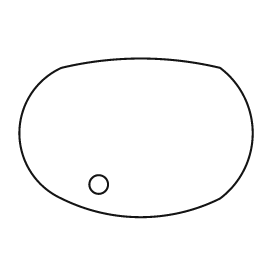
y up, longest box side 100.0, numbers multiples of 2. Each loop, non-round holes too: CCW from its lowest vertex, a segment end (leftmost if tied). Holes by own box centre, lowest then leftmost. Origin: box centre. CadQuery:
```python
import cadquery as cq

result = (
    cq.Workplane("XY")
    .moveTo(-32.0, -26.0)
    .threePointArc((2.0, -34.0), (36.0, -26.0))
    .threePointArc((50.0, 2.0), (36.0, 30.0))
    .threePointArc((2.0, 34.0), (-32.0, 30.0))
    .threePointArc((-50.0, 2.0), (-32.0, -26.0))
    .close()
    .moveTo(-16.0, -20.0)
    .circle(4.0)
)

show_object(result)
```